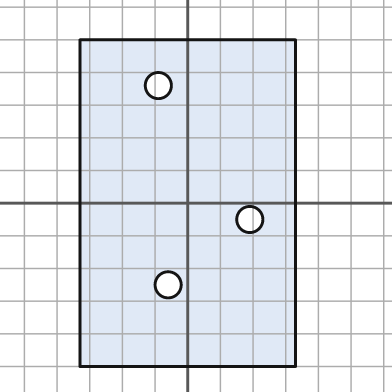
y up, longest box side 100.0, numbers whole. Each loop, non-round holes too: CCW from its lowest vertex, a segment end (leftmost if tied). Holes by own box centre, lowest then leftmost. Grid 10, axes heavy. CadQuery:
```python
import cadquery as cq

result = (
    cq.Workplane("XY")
    .moveTo(-33.0, -50.0)
    .lineTo(33.0, -50.0)
    .lineTo(33.0, 50.0)
    .lineTo(-33.0, 50.0)
    .close()
    .moveTo(-6.0, -25.0)
    .circle(4.0)
    .moveTo(19.0, -5.0)
    .circle(4.0)
    .moveTo(-9.0, 36.0)
    .circle(4.0)
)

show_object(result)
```